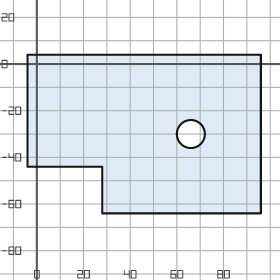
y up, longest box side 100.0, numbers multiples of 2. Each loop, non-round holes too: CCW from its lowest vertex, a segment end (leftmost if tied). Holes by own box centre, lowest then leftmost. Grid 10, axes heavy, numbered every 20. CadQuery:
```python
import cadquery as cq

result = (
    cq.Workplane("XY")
    .moveTo(28.0, -64.0)
    .lineTo(96.0, -64.0)
    .lineTo(96.0, 4.0)
    .lineTo(-4.0, 4.0)
    .lineTo(-4.0, -44.0)
    .lineTo(28.0, -44.0)
    .close()
    .moveTo(66.0, -30.0)
    .circle(6.0)
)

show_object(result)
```